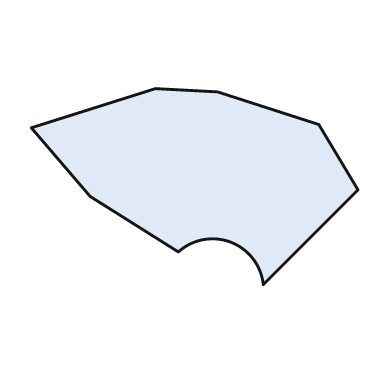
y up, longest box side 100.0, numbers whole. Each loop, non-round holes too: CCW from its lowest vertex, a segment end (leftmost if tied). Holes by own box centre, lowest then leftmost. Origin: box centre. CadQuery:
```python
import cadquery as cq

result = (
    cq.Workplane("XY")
    .moveTo(21.0, -30.0)
    .lineTo(50.0, -1.0)
    .lineTo(38.0, 19.0)
    .lineTo(7.0, 29.0)
    .lineTo(-12.0, 30.0)
    .lineTo(-50.0, 18.0)
    .lineTo(-32.0, -3.0)
    .lineTo(-5.0, -20.0)
    .threePointArc((11.0, -17.0), (21.0, -30.0))
    .close()
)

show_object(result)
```